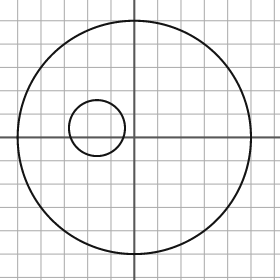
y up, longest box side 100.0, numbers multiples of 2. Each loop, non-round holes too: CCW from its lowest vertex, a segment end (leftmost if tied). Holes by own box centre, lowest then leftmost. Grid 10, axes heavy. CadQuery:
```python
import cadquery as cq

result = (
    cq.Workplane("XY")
    .moveTo(0.0, 0.0)
    .circle(50.0)
    .moveTo(-16.0, 4.0)
    .circle(12.0)
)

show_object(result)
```